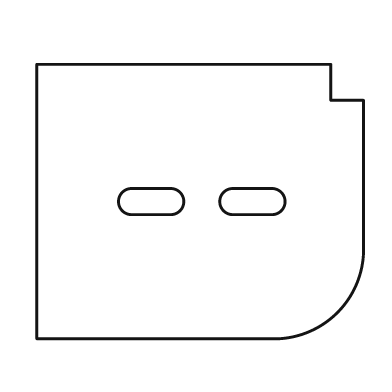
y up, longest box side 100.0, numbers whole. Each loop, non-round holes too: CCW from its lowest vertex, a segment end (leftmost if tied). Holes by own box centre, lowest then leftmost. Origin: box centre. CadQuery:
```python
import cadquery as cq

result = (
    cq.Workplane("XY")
    .moveTo(-50.0, -42.0)
    .lineTo(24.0, -42.0)
    .threePointArc((42.0, -34.0), (50.0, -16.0))
    .lineTo(50.0, 31.0)
    .lineTo(40.0, 31.0)
    .lineTo(40.0, 42.0)
    .lineTo(-50.0, 42.0)
    .close()
    .moveTo(-21.0, -4.0)
    .lineTo(-9.0, -4.0)
    .threePointArc((-5.0, 0.0), (-9.0, 4.0))
    .lineTo(-21.0, 4.0)
    .threePointArc((-25.0, 0.0), (-21.0, -4.0))
    .close()
    .moveTo(10.0, -4.0)
    .lineTo(22.0, -4.0)
    .threePointArc((26.0, 0.0), (22.0, 4.0))
    .lineTo(10.0, 4.0)
    .threePointArc((6.0, 0.0), (10.0, -4.0))
    .close()
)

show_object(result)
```